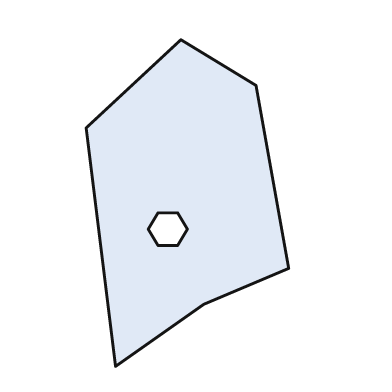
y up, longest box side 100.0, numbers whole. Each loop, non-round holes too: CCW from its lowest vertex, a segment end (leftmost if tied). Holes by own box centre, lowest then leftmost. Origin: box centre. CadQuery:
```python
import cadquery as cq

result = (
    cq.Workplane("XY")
    .moveTo(-22.0, -50.0)
    .lineTo(5.0, -31.0)
    .lineTo(31.0, -20.0)
    .lineTo(21.0, 36.0)
    .lineTo(-2.0, 50.0)
    .lineTo(-31.0, 23.0)
    .close()
    .moveTo(-9.0, -13.0)
    .lineTo(-3.0, -13.0)
    .lineTo(0.0, -8.0)
    .lineTo(-3.0, -3.0)
    .lineTo(-9.0, -3.0)
    .lineTo(-12.0, -8.0)
    .close()
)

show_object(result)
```